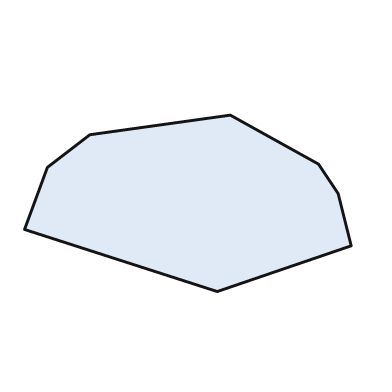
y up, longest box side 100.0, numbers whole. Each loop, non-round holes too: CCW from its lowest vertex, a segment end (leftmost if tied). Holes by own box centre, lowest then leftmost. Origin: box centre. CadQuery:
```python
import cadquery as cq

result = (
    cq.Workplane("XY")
    .moveTo(9.0, -27.0)
    .lineTo(50.0, -13.0)
    .lineTo(46.0, 3.0)
    .lineTo(40.0, 12.0)
    .lineTo(13.0, 27.0)
    .lineTo(-30.0, 21.0)
    .lineTo(-43.0, 11.0)
    .lineTo(-50.0, -8.0)
    .close()
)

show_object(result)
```